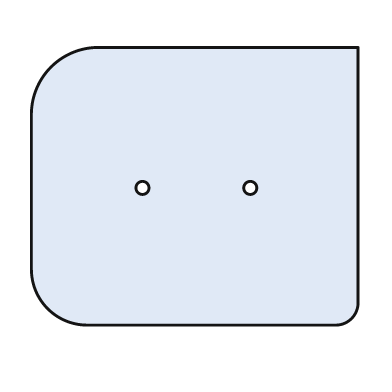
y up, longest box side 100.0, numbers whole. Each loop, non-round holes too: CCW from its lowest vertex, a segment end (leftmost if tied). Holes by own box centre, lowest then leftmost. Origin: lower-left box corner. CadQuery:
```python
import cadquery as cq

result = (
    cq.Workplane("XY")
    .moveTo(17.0, 0.0)
    .lineTo(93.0, 0.0)
    .threePointArc((98.0, 2.0), (100.0, 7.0))
    .lineTo(100.0, 85.0)
    .lineTo(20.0, 85.0)
    .threePointArc((6.0, 79.0), (0.0, 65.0))
    .lineTo(0.0, 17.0)
    .threePointArc((5.0, 5.0), (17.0, 0.0))
    .close()
    .moveTo(34.0, 42.0)
    .circle(2.0)
    .moveTo(67.0, 42.0)
    .circle(2.0)
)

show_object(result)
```